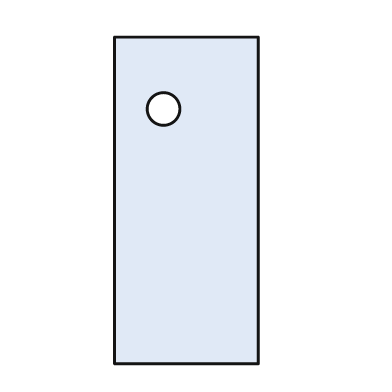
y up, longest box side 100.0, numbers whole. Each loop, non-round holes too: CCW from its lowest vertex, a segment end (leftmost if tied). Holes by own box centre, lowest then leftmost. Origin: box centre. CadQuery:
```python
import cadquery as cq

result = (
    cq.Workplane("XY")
    .moveTo(-22.0, -50.0)
    .lineTo(22.0, -50.0)
    .lineTo(22.0, 50.0)
    .lineTo(-22.0, 50.0)
    .close()
    .moveTo(-7.0, 28.0)
    .circle(5.0)
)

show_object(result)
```